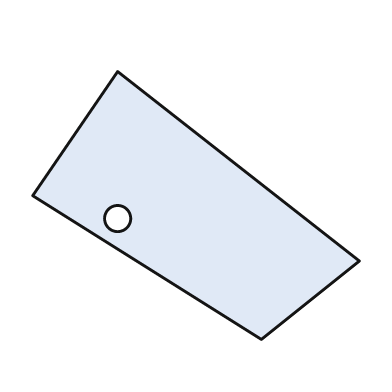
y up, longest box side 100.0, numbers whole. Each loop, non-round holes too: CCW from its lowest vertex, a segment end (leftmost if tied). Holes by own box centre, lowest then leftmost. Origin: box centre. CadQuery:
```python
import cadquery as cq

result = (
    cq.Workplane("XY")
    .moveTo(20.0, -41.0)
    .lineTo(50.0, -17.0)
    .lineTo(-24.0, 41.0)
    .lineTo(-50.0, 3.0)
    .close()
    .moveTo(-24.0, -4.0)
    .circle(4.0)
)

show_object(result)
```